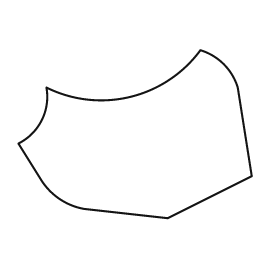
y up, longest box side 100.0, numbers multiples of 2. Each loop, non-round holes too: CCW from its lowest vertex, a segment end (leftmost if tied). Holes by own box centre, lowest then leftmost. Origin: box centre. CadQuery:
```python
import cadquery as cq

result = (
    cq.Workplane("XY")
    .moveTo(14.0, -36.0)
    .lineTo(50.0, -18.0)
    .lineTo(44.0, 20.0)
    .threePointArc((38.0, 30.0), (28.0, 36.0))
    .threePointArc((-2.0, 16.0), (-38.0, 20.0))
    .threePointArc((-40.0, 6.0), (-50.0, -4.0))
    .lineTo(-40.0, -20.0)
    .threePointArc((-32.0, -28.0), (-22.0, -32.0))
    .close()
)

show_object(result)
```